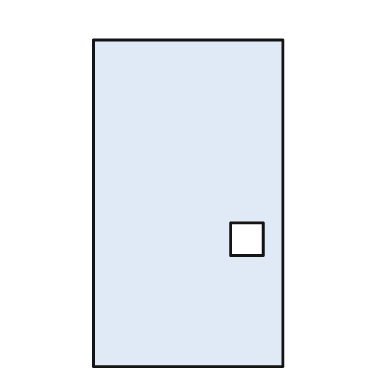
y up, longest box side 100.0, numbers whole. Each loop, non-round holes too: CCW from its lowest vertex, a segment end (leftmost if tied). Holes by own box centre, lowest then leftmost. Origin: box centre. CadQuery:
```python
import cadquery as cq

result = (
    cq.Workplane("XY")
    .moveTo(-29.0, -50.0)
    .lineTo(29.0, -50.0)
    .lineTo(29.0, 50.0)
    .lineTo(-29.0, 50.0)
    .close()
    .moveTo(13.0, -16.0)
    .lineTo(23.0, -16.0)
    .lineTo(23.0, -6.0)
    .lineTo(13.0, -6.0)
    .close()
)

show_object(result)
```